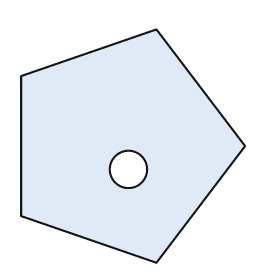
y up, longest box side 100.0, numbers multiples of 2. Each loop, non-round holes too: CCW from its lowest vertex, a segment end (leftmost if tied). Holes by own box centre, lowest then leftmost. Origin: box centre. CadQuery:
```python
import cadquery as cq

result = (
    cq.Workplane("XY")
    .moveTo(10.0, -50.0)
    .lineTo(48.0, 0.0)
    .lineTo(10.0, 50.0)
    .lineTo(-48.0, 30.0)
    .lineTo(-48.0, -30.0)
    .close()
    .moveTo(-2.0, -10.0)
    .circle(8.0)
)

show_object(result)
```